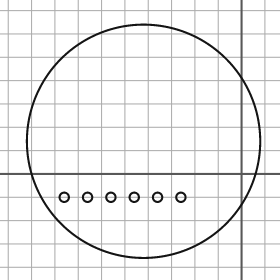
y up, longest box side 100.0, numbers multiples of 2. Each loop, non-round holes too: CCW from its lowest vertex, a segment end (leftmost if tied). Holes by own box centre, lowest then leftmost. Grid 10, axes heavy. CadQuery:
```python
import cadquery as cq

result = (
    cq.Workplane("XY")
    .moveTo(-42.0, 14.0)
    .circle(50.0)
    .moveTo(-76.0, -10.0)
    .circle(2.0)
    .moveTo(-66.0, -10.0)
    .circle(2.0)
    .moveTo(-56.0, -10.0)
    .circle(2.0)
    .moveTo(-46.0, -10.0)
    .circle(2.0)
    .moveTo(-36.0, -10.0)
    .circle(2.0)
    .moveTo(-26.0, -10.0)
    .circle(2.0)
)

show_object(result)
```